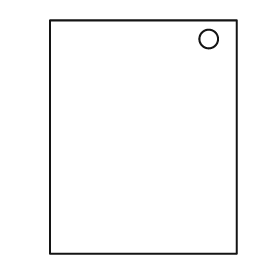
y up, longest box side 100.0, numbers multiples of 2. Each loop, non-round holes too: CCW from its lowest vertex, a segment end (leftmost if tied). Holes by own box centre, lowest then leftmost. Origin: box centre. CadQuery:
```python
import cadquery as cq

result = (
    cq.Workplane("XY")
    .moveTo(-40.0, -50.0)
    .lineTo(40.0, -50.0)
    .lineTo(40.0, 50.0)
    .lineTo(-40.0, 50.0)
    .close()
    .moveTo(28.0, 42.0)
    .circle(4.0)
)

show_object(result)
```